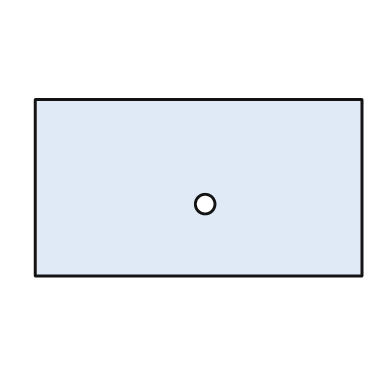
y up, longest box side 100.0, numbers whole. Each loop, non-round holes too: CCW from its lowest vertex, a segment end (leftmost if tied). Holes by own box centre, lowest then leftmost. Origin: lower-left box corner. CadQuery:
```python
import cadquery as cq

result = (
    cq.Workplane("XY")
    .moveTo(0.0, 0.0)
    .lineTo(100.0, 0.0)
    .lineTo(100.0, 54.0)
    .lineTo(0.0, 54.0)
    .close()
    .moveTo(52.0, 22.0)
    .circle(3.0)
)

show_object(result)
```